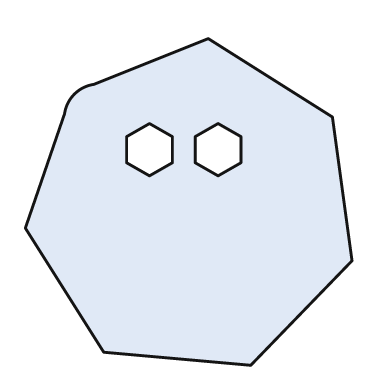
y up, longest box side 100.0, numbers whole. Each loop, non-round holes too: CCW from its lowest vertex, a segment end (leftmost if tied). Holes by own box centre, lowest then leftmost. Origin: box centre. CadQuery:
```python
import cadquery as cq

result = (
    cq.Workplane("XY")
    .moveTo(19.0, -50.0)
    .lineTo(50.0, -18.0)
    .lineTo(44.0, 26.0)
    .lineTo(6.0, 50.0)
    .lineTo(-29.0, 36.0)
    .threePointArc((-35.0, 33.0), (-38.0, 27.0))
    .lineTo(-50.0, -8.0)
    .lineTo(-26.0, -46.0)
    .close()
    .moveTo(-12.0, 8.0)
    .lineTo(-5.0, 12.0)
    .lineTo(-5.0, 20.0)
    .lineTo(-12.0, 24.0)
    .lineTo(-19.0, 20.0)
    .lineTo(-19.0, 12.0)
    .close()
    .moveTo(9.0, 8.0)
    .lineTo(16.0, 12.0)
    .lineTo(16.0, 20.0)
    .lineTo(9.0, 24.0)
    .lineTo(2.0, 20.0)
    .lineTo(2.0, 12.0)
    .close()
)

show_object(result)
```